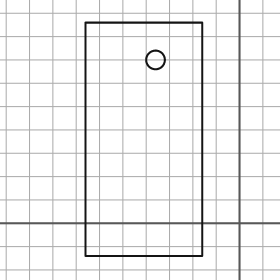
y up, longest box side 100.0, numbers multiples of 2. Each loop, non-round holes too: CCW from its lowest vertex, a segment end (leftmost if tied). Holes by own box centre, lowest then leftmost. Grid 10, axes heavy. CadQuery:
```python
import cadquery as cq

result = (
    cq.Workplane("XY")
    .moveTo(-66.0, -14.0)
    .lineTo(-16.0, -14.0)
    .lineTo(-16.0, 86.0)
    .lineTo(-66.0, 86.0)
    .close()
    .moveTo(-36.0, 70.0)
    .circle(4.0)
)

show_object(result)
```